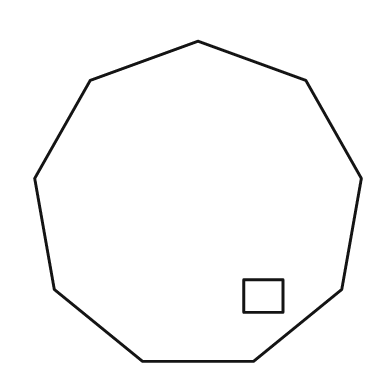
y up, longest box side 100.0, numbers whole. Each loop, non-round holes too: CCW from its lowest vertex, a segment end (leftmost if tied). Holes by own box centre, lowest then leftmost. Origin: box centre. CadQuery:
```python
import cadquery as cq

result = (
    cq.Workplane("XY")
    .moveTo(-17.0, -49.0)
    .lineTo(17.0, -49.0)
    .lineTo(44.0, -27.0)
    .lineTo(50.0, 7.0)
    .lineTo(33.0, 37.0)
    .lineTo(0.0, 49.0)
    .lineTo(-33.0, 37.0)
    .lineTo(-50.0, 7.0)
    .lineTo(-44.0, -27.0)
    .close()
    .moveTo(14.0, -34.0)
    .lineTo(26.0, -34.0)
    .lineTo(26.0, -24.0)
    .lineTo(14.0, -24.0)
    .close()
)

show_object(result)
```